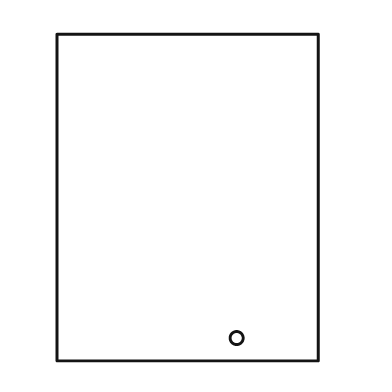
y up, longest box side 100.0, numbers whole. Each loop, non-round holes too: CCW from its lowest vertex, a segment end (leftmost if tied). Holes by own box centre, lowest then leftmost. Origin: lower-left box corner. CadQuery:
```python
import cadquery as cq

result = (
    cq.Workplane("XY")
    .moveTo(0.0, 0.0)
    .lineTo(80.0, 0.0)
    .lineTo(80.0, 100.0)
    .lineTo(0.0, 100.0)
    .close()
    .moveTo(55.0, 7.0)
    .circle(2.0)
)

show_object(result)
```